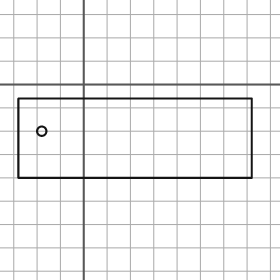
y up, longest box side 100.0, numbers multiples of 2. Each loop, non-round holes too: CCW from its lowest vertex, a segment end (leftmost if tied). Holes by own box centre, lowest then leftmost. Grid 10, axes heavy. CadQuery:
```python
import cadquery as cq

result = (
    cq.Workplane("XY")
    .moveTo(-28.0, -40.0)
    .lineTo(72.0, -40.0)
    .lineTo(72.0, -6.0)
    .lineTo(-28.0, -6.0)
    .close()
    .moveTo(-18.0, -20.0)
    .circle(2.0)
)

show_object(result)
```